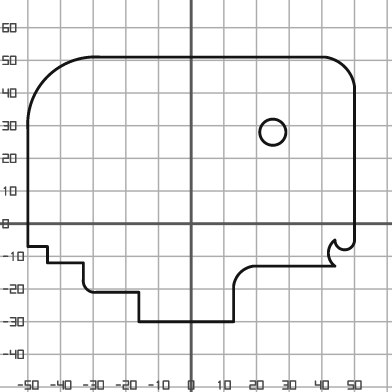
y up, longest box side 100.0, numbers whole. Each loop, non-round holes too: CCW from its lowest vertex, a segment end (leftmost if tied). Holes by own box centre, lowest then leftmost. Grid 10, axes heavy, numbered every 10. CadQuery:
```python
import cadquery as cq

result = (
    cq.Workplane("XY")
    .moveTo(-16.0, -30.0)
    .lineTo(13.0, -30.0)
    .lineTo(13.0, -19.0)
    .threePointArc((15.0, -15.0), (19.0, -13.0))
    .lineTo(44.0, -13.0)
    .threePointArc((42.0, -9.0), (44.0, -5.0))
    .threePointArc((47.0, -8.0), (50.0, -5.0))
    .lineTo(50.0, 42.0)
    .threePointArc((47.0, 48.0), (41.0, 51.0))
    .lineTo(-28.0, 51.0)
    .threePointArc((-44.0, 45.0), (-50.0, 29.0))
    .lineTo(-50.0, -7.0)
    .lineTo(-44.0, -7.0)
    .lineTo(-44.0, -12.0)
    .lineTo(-33.0, -12.0)
    .lineTo(-33.0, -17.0)
    .threePointArc((-32.0, -20.0), (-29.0, -21.0))
    .lineTo(-16.0, -21.0)
    .close()
    .moveTo(25.0, 28.0)
    .circle(4.0)
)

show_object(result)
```